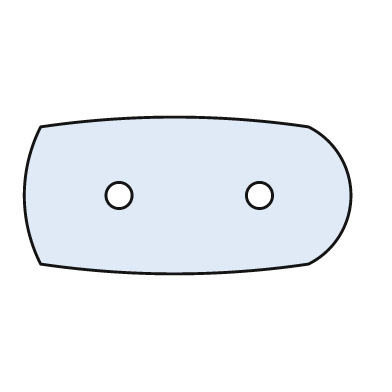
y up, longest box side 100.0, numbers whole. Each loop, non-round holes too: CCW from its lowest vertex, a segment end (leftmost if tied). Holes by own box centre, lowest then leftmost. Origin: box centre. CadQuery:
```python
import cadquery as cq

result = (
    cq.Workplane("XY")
    .moveTo(-45.0, -21.0)
    .threePointArc((-4.0, -24.0), (37.0, -21.0))
    .threePointArc((50.0, 0.0), (37.0, 21.0))
    .threePointArc((-4.0, 24.0), (-45.0, 21.0))
    .threePointArc((-50.0, 0.0), (-45.0, -21.0))
    .close()
    .moveTo(-21.0, 0.0)
    .circle(4.0)
    .moveTo(22.0, 0.0)
    .circle(4.0)
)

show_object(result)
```